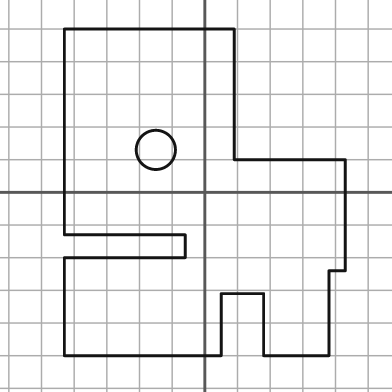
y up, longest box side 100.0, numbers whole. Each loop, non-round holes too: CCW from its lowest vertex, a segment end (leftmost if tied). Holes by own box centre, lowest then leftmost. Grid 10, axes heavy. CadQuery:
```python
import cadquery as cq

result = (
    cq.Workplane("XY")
    .moveTo(-43.0, -50.0)
    .lineTo(5.0, -50.0)
    .lineTo(5.0, -31.0)
    .lineTo(18.0, -31.0)
    .lineTo(18.0, -50.0)
    .lineTo(38.0, -50.0)
    .lineTo(38.0, -24.0)
    .lineTo(43.0, -24.0)
    .lineTo(43.0, 10.0)
    .lineTo(9.0, 10.0)
    .lineTo(9.0, 50.0)
    .lineTo(-43.0, 50.0)
    .lineTo(-43.0, -13.0)
    .lineTo(-6.0, -13.0)
    .lineTo(-6.0, -20.0)
    .lineTo(-43.0, -20.0)
    .close()
    .moveTo(-15.0, 13.0)
    .circle(6.0)
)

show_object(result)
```